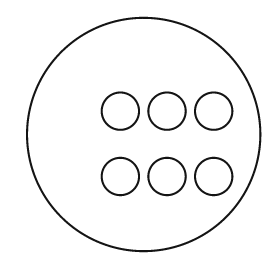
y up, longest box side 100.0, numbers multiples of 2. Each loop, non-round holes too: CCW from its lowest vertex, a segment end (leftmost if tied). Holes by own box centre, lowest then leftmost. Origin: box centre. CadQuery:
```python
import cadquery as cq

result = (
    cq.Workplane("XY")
    .moveTo(0.0, 0.0)
    .circle(50.0)
    .moveTo(-10.0, -18.0)
    .circle(8.0)
    .moveTo(10.0, -18.0)
    .circle(8.0)
    .moveTo(30.0, -18.0)
    .circle(8.0)
    .moveTo(-10.0, 10.0)
    .circle(8.0)
    .moveTo(10.0, 10.0)
    .circle(8.0)
    .moveTo(30.0, 10.0)
    .circle(8.0)
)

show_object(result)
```